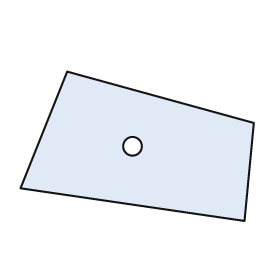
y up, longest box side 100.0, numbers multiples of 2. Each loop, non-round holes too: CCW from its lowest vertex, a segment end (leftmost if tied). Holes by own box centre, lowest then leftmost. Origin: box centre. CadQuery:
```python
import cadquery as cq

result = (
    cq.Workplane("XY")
    .moveTo(46.0, -32.0)
    .lineTo(50.0, 10.0)
    .lineTo(-30.0, 32.0)
    .lineTo(-50.0, -18.0)
    .close()
    .moveTo(-2.0, 0.0)
    .circle(4.0)
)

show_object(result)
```